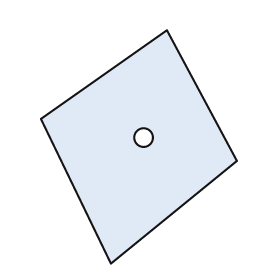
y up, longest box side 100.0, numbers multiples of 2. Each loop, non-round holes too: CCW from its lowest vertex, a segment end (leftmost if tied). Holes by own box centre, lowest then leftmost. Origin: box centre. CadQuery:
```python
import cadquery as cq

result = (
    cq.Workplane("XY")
    .moveTo(-12.0, -50.0)
    .lineTo(42.0, -6.0)
    .lineTo(12.0, 50.0)
    .lineTo(-42.0, 12.0)
    .close()
    .moveTo(2.0, 4.0)
    .circle(4.0)
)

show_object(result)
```